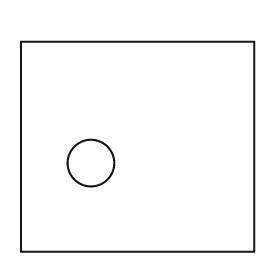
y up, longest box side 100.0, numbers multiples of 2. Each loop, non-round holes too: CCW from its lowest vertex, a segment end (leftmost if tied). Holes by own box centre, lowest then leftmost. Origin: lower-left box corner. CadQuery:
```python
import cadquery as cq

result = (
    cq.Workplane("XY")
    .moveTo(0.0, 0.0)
    .lineTo(100.0, 0.0)
    .lineTo(100.0, 90.0)
    .lineTo(0.0, 90.0)
    .close()
    .moveTo(30.0, 38.0)
    .circle(10.0)
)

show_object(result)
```